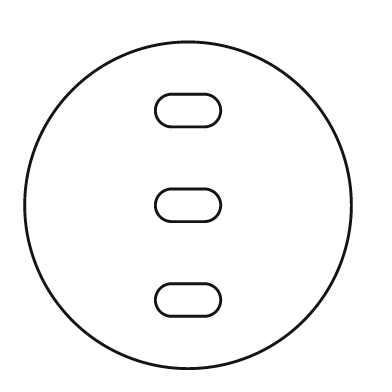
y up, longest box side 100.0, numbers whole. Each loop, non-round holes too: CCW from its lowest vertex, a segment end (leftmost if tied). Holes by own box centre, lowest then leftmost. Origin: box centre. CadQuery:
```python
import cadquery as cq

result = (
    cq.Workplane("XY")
    .moveTo(0.0, 0.0)
    .circle(50.0)
    .moveTo(-5.0, -34.0)
    .lineTo(5.0, -34.0)
    .threePointArc((10.0, -29.0), (5.0, -24.0))
    .lineTo(-5.0, -24.0)
    .threePointArc((-10.0, -29.0), (-5.0, -34.0))
    .close()
    .moveTo(-5.0, -5.0)
    .lineTo(5.0, -5.0)
    .threePointArc((10.0, 0.0), (5.0, 5.0))
    .lineTo(-5.0, 5.0)
    .threePointArc((-10.0, 0.0), (-5.0, -5.0))
    .close()
    .moveTo(-5.0, 24.0)
    .lineTo(5.0, 24.0)
    .threePointArc((10.0, 29.0), (5.0, 34.0))
    .lineTo(-5.0, 34.0)
    .threePointArc((-10.0, 29.0), (-5.0, 24.0))
    .close()
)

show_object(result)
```